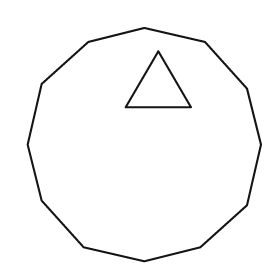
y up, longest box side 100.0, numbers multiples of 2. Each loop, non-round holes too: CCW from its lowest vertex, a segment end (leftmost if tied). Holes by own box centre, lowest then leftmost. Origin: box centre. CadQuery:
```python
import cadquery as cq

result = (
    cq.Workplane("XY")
    .moveTo(0.0, -50.0)
    .lineTo(24.0, -44.0)
    .lineTo(44.0, -26.0)
    .lineTo(50.0, 0.0)
    .lineTo(44.0, 24.0)
    .lineTo(26.0, 44.0)
    .lineTo(0.0, 50.0)
    .lineTo(-24.0, 44.0)
    .lineTo(-44.0, 26.0)
    .lineTo(-50.0, 0.0)
    .lineTo(-44.0, -24.0)
    .lineTo(-26.0, -44.0)
    .close()
    .moveTo(-8.0, 16.0)
    .lineTo(20.0, 16.0)
    .lineTo(6.0, 40.0)
    .close()
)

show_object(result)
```